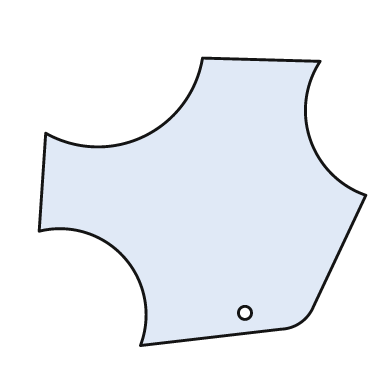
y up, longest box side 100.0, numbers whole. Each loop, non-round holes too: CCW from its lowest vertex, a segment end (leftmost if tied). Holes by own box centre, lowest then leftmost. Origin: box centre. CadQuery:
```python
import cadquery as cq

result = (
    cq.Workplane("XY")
    .moveTo(-19.0, -44.0)
    .lineTo(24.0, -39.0)
    .threePointArc((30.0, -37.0), (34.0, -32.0))
    .lineTo(50.0, 2.0)
    .threePointArc((33.0, 19.0), (36.0, 43.0))
    .lineTo(0.0, 44.0)
    .threePointArc((-18.0, 20.0), (-48.0, 21.0))
    .lineTo(-50.0, -9.0)
    .threePointArc((-24.0, -17.0), (-19.0, -44.0))
    .close()
    .moveTo(13.0, -34.0)
    .circle(2.0)
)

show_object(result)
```